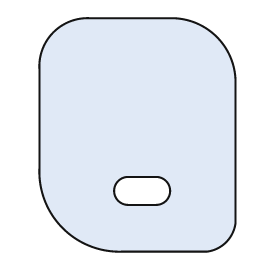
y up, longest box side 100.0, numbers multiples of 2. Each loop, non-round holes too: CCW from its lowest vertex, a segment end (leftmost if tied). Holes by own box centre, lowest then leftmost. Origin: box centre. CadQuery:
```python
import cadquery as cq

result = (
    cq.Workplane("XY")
    .moveTo(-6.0, -50.0)
    .lineTo(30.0, -50.0)
    .threePointArc((38.0, -46.0), (42.0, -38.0))
    .lineTo(42.0, 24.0)
    .threePointArc((34.0, 42.0), (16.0, 50.0))
    .lineTo(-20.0, 50.0)
    .threePointArc((-36.0, 44.0), (-42.0, 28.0))
    .lineTo(-42.0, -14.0)
    .threePointArc((-32.0, -40.0), (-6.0, -50.0))
    .close()
    .moveTo(-4.0, -30.0)
    .lineTo(8.0, -30.0)
    .threePointArc((14.0, -24.0), (8.0, -18.0))
    .lineTo(-4.0, -18.0)
    .threePointArc((-10.0, -24.0), (-4.0, -30.0))
    .close()
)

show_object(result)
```